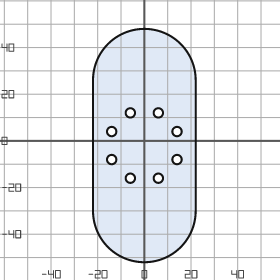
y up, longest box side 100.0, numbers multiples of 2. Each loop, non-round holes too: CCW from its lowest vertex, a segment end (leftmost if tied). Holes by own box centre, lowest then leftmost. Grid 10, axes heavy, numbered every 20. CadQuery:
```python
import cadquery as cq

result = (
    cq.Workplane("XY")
    .moveTo(-22.0, -30.0)
    .threePointArc((0.0, -52.0), (22.0, -30.0))
    .lineTo(22.0, 26.0)
    .threePointArc((0.0, 48.0), (-22.0, 26.0))
    .close()
    .moveTo(-6.0, -16.0)
    .circle(2.0)
    .moveTo(6.0, -16.0)
    .circle(2.0)
    .moveTo(-14.0, -8.0)
    .circle(2.0)
    .moveTo(14.0, -8.0)
    .circle(2.0)
    .moveTo(-14.0, 4.0)
    .circle(2.0)
    .moveTo(14.0, 4.0)
    .circle(2.0)
    .moveTo(-6.0, 12.0)
    .circle(2.0)
    .moveTo(6.0, 12.0)
    .circle(2.0)
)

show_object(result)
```